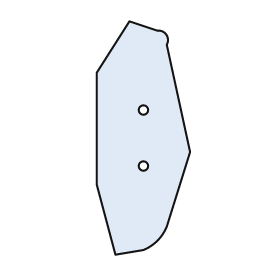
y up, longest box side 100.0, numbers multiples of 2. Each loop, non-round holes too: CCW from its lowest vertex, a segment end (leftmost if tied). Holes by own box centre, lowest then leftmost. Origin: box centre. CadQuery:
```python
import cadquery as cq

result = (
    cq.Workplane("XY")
    .moveTo(-12.0, -50.0)
    .lineTo(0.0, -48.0)
    .threePointArc((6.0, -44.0), (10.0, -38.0))
    .lineTo(20.0, -6.0)
    .lineTo(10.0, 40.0)
    .threePointArc((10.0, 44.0), (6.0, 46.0))
    .lineTo(-6.0, 50.0)
    .lineTo(-20.0, 28.0)
    .lineTo(-20.0, -20.0)
    .close()
    .moveTo(0.0, -12.0)
    .circle(2.0)
    .moveTo(0.0, 12.0)
    .circle(2.0)
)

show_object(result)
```